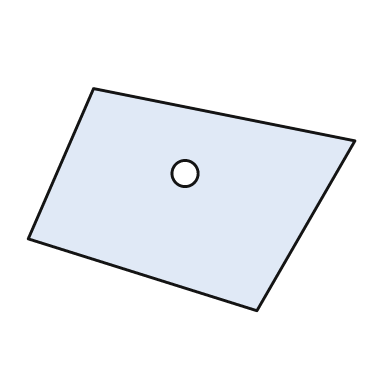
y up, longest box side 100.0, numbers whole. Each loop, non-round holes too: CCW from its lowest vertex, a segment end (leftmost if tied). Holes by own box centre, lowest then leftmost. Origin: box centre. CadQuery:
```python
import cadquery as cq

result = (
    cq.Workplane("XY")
    .moveTo(20.0, -34.0)
    .lineTo(50.0, 18.0)
    .lineTo(-30.0, 34.0)
    .lineTo(-50.0, -12.0)
    .close()
    .moveTo(-2.0, 8.0)
    .circle(4.0)
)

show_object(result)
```